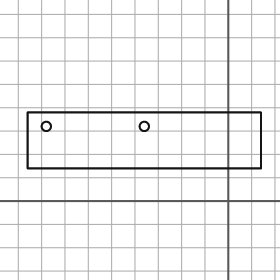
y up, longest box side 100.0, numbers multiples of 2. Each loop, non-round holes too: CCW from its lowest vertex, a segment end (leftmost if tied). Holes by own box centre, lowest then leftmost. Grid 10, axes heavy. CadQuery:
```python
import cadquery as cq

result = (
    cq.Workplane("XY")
    .moveTo(-86.0, 14.0)
    .lineTo(14.0, 14.0)
    .lineTo(14.0, 38.0)
    .lineTo(-86.0, 38.0)
    .close()
    .moveTo(-78.0, 32.0)
    .circle(2.0)
    .moveTo(-36.0, 32.0)
    .circle(2.0)
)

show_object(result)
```